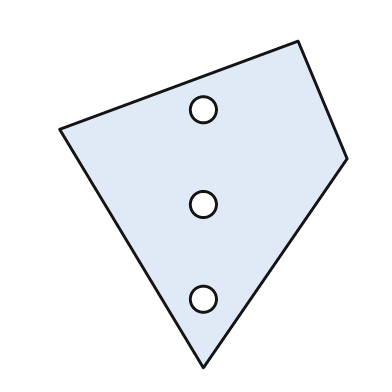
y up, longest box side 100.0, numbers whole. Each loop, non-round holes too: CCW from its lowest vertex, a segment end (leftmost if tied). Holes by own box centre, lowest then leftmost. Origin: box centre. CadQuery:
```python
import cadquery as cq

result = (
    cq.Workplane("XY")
    .moveTo(0.0, -50.0)
    .lineTo(44.0, 14.0)
    .lineTo(29.0, 50.0)
    .lineTo(-44.0, 23.0)
    .close()
    .moveTo(0.0, -29.0)
    .circle(4.0)
    .moveTo(0.0, 0.0)
    .circle(4.0)
    .moveTo(0.0, 29.0)
    .circle(4.0)
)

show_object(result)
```